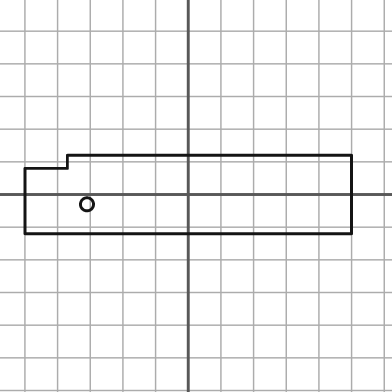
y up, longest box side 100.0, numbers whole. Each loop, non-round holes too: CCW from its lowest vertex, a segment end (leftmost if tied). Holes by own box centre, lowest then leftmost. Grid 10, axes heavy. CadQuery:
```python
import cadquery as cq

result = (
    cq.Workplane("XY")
    .moveTo(-50.0, -12.0)
    .lineTo(50.0, -12.0)
    .lineTo(50.0, 12.0)
    .lineTo(-37.0, 12.0)
    .lineTo(-37.0, 8.0)
    .lineTo(-50.0, 8.0)
    .close()
    .moveTo(-31.0, -3.0)
    .circle(2.0)
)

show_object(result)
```